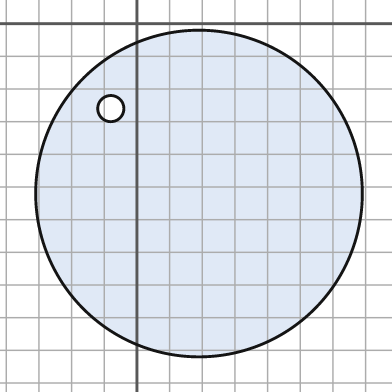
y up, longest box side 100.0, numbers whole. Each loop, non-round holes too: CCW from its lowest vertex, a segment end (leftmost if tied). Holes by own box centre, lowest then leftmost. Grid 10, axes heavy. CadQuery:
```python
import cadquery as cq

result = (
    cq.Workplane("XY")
    .moveTo(19.0, -52.0)
    .circle(50.0)
    .moveTo(-8.0, -26.0)
    .circle(4.0)
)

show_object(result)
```